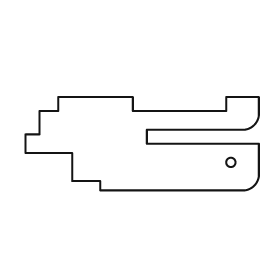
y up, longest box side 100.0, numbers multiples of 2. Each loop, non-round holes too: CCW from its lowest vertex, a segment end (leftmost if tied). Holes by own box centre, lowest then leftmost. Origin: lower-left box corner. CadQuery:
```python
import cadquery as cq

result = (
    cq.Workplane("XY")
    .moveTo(32.0, 0.0)
    .lineTo(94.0, 0.0)
    .threePointArc((98.0, 2.0), (100.0, 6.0))
    .lineTo(100.0, 20.0)
    .lineTo(52.0, 20.0)
    .lineTo(52.0, 26.0)
    .lineTo(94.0, 26.0)
    .threePointArc((98.0, 28.0), (100.0, 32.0))
    .lineTo(100.0, 40.0)
    .lineTo(86.0, 40.0)
    .lineTo(86.0, 34.0)
    .lineTo(46.0, 34.0)
    .lineTo(46.0, 40.0)
    .lineTo(14.0, 40.0)
    .lineTo(14.0, 34.0)
    .lineTo(6.0, 34.0)
    .lineTo(6.0, 24.0)
    .lineTo(0.0, 24.0)
    .lineTo(0.0, 16.0)
    .lineTo(20.0, 16.0)
    .lineTo(20.0, 4.0)
    .lineTo(32.0, 4.0)
    .close()
    .moveTo(88.0, 12.0)
    .circle(2.0)
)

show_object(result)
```